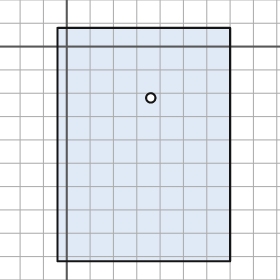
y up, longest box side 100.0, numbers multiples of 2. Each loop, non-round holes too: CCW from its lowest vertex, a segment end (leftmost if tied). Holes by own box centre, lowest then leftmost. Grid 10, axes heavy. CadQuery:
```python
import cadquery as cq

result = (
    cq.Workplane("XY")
    .moveTo(-4.0, -92.0)
    .lineTo(70.0, -92.0)
    .lineTo(70.0, 8.0)
    .lineTo(-4.0, 8.0)
    .close()
    .moveTo(36.0, -22.0)
    .circle(2.0)
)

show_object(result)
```